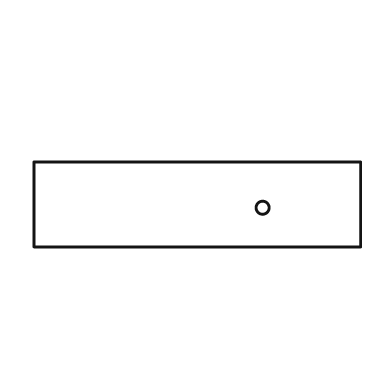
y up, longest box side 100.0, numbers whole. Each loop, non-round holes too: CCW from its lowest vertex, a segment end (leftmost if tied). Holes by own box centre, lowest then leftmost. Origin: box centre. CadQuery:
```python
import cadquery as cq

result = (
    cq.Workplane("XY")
    .moveTo(-50.0, -13.0)
    .lineTo(50.0, -13.0)
    .lineTo(50.0, 13.0)
    .lineTo(-50.0, 13.0)
    .close()
    .moveTo(20.0, -1.0)
    .circle(2.0)
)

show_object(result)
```